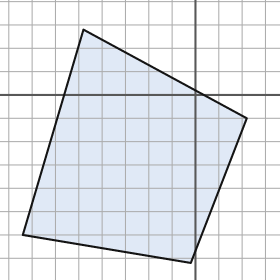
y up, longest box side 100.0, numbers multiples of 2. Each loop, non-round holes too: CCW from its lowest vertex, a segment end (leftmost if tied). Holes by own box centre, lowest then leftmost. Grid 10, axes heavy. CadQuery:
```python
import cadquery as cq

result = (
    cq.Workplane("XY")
    .moveTo(-2.0, -72.0)
    .lineTo(22.0, -10.0)
    .lineTo(-48.0, 28.0)
    .lineTo(-74.0, -60.0)
    .close()
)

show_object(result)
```